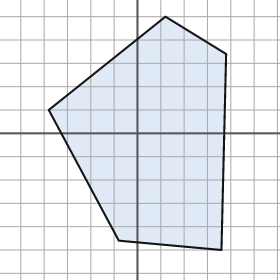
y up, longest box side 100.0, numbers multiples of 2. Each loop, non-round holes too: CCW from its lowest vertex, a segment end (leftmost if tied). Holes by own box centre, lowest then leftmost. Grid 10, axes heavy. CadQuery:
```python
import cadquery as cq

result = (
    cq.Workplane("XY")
    .moveTo(36.0, -50.0)
    .lineTo(38.0, 34.0)
    .lineTo(12.0, 50.0)
    .lineTo(-38.0, 10.0)
    .lineTo(-8.0, -46.0)
    .close()
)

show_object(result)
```